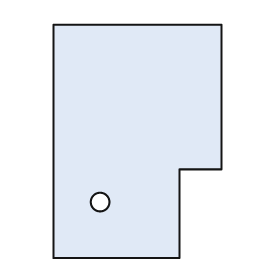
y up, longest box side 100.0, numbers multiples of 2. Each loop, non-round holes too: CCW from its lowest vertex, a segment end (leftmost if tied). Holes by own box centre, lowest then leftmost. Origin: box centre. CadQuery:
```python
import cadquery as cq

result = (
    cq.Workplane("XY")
    .moveTo(-36.0, -50.0)
    .lineTo(18.0, -50.0)
    .lineTo(18.0, -12.0)
    .lineTo(36.0, -12.0)
    .lineTo(36.0, 50.0)
    .lineTo(-36.0, 50.0)
    .close()
    .moveTo(-16.0, -26.0)
    .circle(4.0)
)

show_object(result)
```